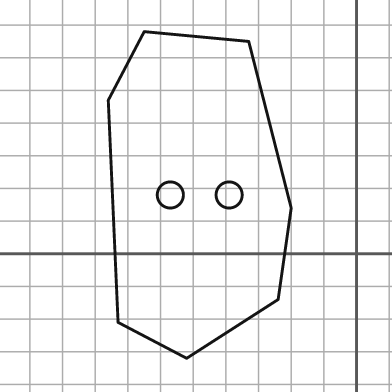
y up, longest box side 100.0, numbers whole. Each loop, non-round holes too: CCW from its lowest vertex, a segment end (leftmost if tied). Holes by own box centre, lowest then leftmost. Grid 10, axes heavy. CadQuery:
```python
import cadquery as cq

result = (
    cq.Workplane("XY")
    .moveTo(-52.0, -32.0)
    .lineTo(-24.0, -14.0)
    .lineTo(-20.0, 14.0)
    .lineTo(-33.0, 65.0)
    .lineTo(-65.0, 68.0)
    .lineTo(-76.0, 47.0)
    .lineTo(-73.0, -21.0)
    .close()
    .moveTo(-57.0, 18.0)
    .circle(4.0)
    .moveTo(-39.0, 18.0)
    .circle(4.0)
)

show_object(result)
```